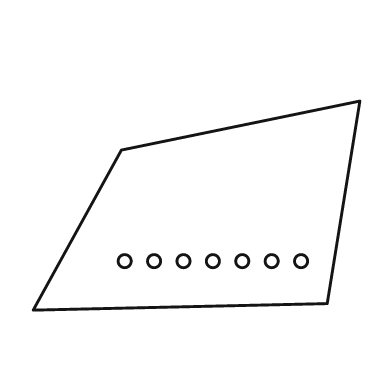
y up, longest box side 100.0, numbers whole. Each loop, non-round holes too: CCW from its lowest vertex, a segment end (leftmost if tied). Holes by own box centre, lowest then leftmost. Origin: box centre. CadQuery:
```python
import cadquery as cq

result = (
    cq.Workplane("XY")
    .moveTo(-50.0, -32.0)
    .lineTo(40.0, -30.0)
    .lineTo(50.0, 32.0)
    .lineTo(-23.0, 17.0)
    .close()
    .moveTo(-22.0, -17.0)
    .circle(2.0)
    .moveTo(-13.0, -17.0)
    .circle(2.0)
    .moveTo(-4.0, -17.0)
    .circle(2.0)
    .moveTo(5.0, -17.0)
    .circle(2.0)
    .moveTo(14.0, -17.0)
    .circle(2.0)
    .moveTo(23.0, -17.0)
    .circle(2.0)
    .moveTo(32.0, -17.0)
    .circle(2.0)
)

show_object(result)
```